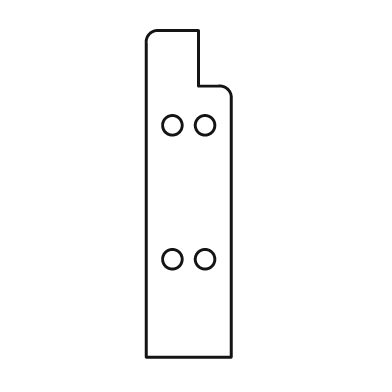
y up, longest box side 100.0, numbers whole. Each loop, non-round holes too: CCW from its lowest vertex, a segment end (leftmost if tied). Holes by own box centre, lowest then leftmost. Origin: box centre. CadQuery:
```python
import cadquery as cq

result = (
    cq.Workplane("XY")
    .moveTo(-13.0, -50.0)
    .lineTo(13.0, -50.0)
    .lineTo(13.0, 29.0)
    .threePointArc((12.0, 32.0), (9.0, 33.0))
    .lineTo(3.0, 33.0)
    .lineTo(3.0, 50.0)
    .lineTo(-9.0, 50.0)
    .threePointArc((-12.0, 49.0), (-13.0, 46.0))
    .close()
    .moveTo(-5.0, -20.0)
    .circle(3.0)
    .moveTo(5.0, -20.0)
    .circle(3.0)
    .moveTo(-5.0, 21.0)
    .circle(3.0)
    .moveTo(5.0, 21.0)
    .circle(3.0)
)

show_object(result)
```